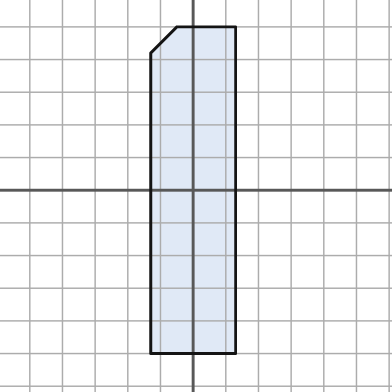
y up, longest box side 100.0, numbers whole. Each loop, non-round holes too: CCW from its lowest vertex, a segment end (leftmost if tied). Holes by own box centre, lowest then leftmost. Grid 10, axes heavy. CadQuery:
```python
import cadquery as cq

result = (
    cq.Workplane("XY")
    .moveTo(-13.0, -50.0)
    .lineTo(13.0, -50.0)
    .lineTo(13.0, 50.0)
    .lineTo(-5.0, 50.0)
    .lineTo(-13.0, 42.0)
    .close()
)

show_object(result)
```